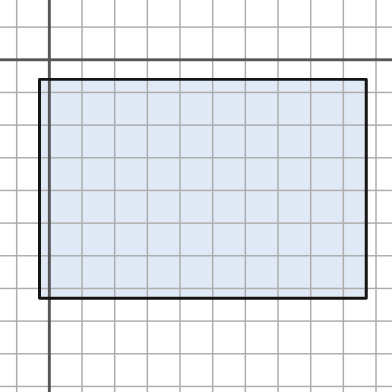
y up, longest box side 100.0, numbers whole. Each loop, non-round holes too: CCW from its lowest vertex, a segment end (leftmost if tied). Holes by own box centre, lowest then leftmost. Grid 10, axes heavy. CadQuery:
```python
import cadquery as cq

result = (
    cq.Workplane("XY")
    .moveTo(-3.0, -73.0)
    .lineTo(97.0, -73.0)
    .lineTo(97.0, -6.0)
    .lineTo(-3.0, -6.0)
    .close()
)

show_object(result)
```